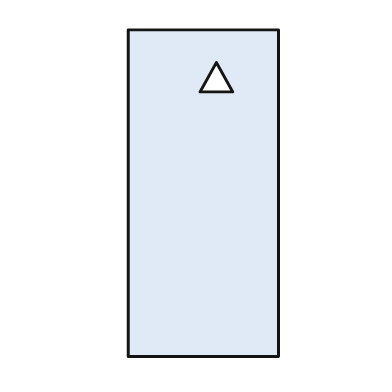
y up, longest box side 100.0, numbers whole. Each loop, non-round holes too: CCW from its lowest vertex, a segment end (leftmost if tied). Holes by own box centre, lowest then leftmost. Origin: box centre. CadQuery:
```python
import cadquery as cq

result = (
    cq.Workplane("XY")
    .moveTo(-23.0, -50.0)
    .lineTo(23.0, -50.0)
    .lineTo(23.0, 50.0)
    .lineTo(-23.0, 50.0)
    .close()
    .moveTo(-1.0, 31.0)
    .lineTo(9.0, 31.0)
    .lineTo(4.0, 40.0)
    .close()
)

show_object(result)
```